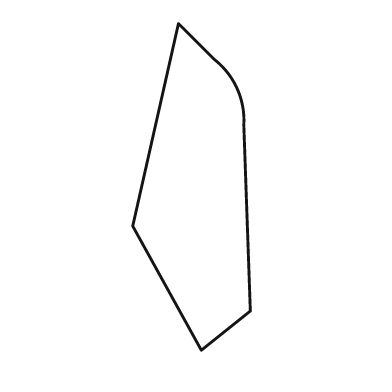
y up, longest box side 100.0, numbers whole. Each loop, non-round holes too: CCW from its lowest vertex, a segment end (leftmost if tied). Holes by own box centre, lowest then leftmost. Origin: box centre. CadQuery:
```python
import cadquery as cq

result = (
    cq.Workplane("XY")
    .moveTo(3.0, -50.0)
    .lineTo(18.0, -38.0)
    .lineTo(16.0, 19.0)
    .threePointArc((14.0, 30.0), (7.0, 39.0))
    .lineTo(-4.0, 50.0)
    .lineTo(-18.0, -12.0)
    .close()
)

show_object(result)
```